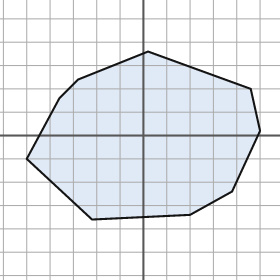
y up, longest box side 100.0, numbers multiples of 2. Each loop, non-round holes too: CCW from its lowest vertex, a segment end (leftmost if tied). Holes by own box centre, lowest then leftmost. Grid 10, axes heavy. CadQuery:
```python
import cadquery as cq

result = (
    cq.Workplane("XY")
    .moveTo(-22.0, -36.0)
    .lineTo(20.0, -34.0)
    .lineTo(38.0, -24.0)
    .lineTo(50.0, 2.0)
    .lineTo(46.0, 20.0)
    .lineTo(2.0, 36.0)
    .lineTo(-28.0, 24.0)
    .lineTo(-36.0, 16.0)
    .lineTo(-50.0, -10.0)
    .close()
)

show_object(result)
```